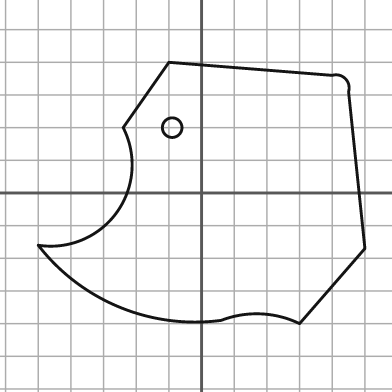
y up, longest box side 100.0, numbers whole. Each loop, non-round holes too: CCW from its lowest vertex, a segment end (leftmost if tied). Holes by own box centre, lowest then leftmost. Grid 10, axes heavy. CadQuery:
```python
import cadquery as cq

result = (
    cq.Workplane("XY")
    .moveTo(30.0, -40.0)
    .lineTo(50.0, -17.0)
    .lineTo(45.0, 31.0)
    .threePointArc((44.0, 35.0), (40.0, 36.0))
    .lineTo(-10.0, 40.0)
    .lineTo(-24.0, 20.0)
    .threePointArc((-26.0, -6.0), (-50.0, -16.0))
    .threePointArc((-25.0, -35.0), (6.0, -39.0))
    .threePointArc((18.0, -37.0), (30.0, -40.0))
    .close()
    .moveTo(-9.0, 20.0)
    .circle(3.0)
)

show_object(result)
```